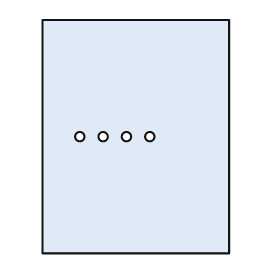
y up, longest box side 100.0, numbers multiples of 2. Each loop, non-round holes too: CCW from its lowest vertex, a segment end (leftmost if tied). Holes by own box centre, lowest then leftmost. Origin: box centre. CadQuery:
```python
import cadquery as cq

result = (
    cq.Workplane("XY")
    .moveTo(-40.0, -50.0)
    .lineTo(40.0, -50.0)
    .lineTo(40.0, 50.0)
    .lineTo(-40.0, 50.0)
    .close()
    .moveTo(-24.0, 0.0)
    .circle(2.0)
    .moveTo(-14.0, 0.0)
    .circle(2.0)
    .moveTo(-4.0, 0.0)
    .circle(2.0)
    .moveTo(6.0, 0.0)
    .circle(2.0)
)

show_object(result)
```